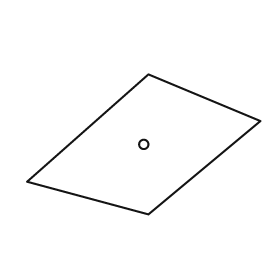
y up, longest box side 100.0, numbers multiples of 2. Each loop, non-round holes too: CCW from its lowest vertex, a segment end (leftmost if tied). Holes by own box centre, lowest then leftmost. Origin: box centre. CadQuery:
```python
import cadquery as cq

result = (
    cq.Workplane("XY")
    .moveTo(2.0, -30.0)
    .lineTo(50.0, 10.0)
    .lineTo(2.0, 30.0)
    .lineTo(-50.0, -16.0)
    .close()
    .moveTo(0.0, 0.0)
    .circle(2.0)
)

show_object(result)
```